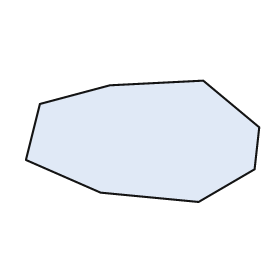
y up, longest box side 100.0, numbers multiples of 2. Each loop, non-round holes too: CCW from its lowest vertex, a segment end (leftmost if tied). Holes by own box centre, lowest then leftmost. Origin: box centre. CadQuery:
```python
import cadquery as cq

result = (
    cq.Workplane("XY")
    .moveTo(24.0, -26.0)
    .lineTo(48.0, -12.0)
    .lineTo(50.0, 6.0)
    .lineTo(26.0, 26.0)
    .lineTo(-14.0, 24.0)
    .lineTo(-44.0, 16.0)
    .lineTo(-50.0, -8.0)
    .lineTo(-18.0, -22.0)
    .close()
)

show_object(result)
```